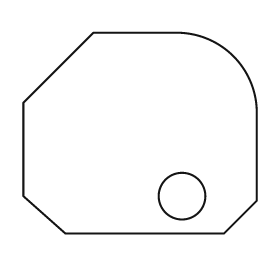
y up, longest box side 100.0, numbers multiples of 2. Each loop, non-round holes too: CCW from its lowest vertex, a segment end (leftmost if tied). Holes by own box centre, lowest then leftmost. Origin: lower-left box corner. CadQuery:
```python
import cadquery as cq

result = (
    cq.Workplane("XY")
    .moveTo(18.0, 0.0)
    .lineTo(86.0, 0.0)
    .lineTo(100.0, 14.0)
    .lineTo(100.0, 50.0)
    .threePointArc((90.0, 76.0), (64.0, 86.0))
    .lineTo(30.0, 86.0)
    .lineTo(0.0, 56.0)
    .lineTo(0.0, 16.0)
    .close()
    .moveTo(68.0, 16.0)
    .circle(10.0)
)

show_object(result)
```